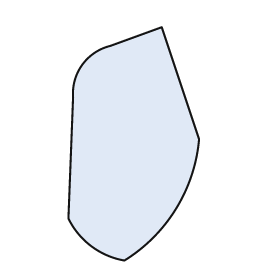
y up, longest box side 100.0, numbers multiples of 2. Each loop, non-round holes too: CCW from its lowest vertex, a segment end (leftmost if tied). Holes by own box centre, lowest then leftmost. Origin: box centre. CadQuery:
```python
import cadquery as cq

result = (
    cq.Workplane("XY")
    .moveTo(-4.0, -50.0)
    .threePointArc((18.0, -28.0), (28.0, 2.0))
    .lineTo(12.0, 50.0)
    .lineTo(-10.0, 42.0)
    .threePointArc((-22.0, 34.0), (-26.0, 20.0))
    .lineTo(-28.0, -32.0)
    .threePointArc((-18.0, -44.0), (-4.0, -50.0))
    .close()
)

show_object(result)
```